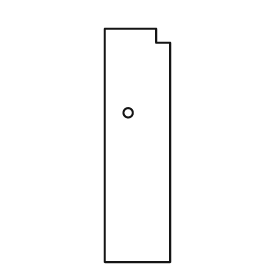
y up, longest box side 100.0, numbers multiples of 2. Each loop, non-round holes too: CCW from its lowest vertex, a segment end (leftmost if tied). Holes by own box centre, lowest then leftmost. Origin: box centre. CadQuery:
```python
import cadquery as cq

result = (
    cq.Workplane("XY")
    .moveTo(-14.0, -50.0)
    .lineTo(14.0, -50.0)
    .lineTo(14.0, 44.0)
    .lineTo(8.0, 44.0)
    .lineTo(8.0, 50.0)
    .lineTo(-14.0, 50.0)
    .close()
    .moveTo(-4.0, 14.0)
    .circle(2.0)
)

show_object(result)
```